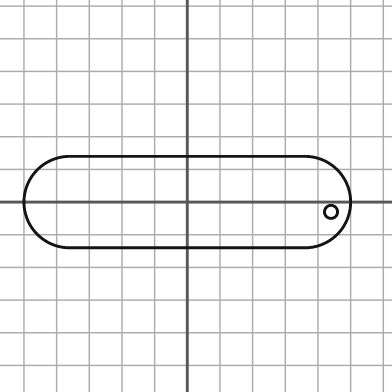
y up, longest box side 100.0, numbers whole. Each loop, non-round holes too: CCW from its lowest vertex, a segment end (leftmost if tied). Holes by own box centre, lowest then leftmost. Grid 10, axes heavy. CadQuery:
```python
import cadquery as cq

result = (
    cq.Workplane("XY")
    .moveTo(-36.0, -14.0)
    .lineTo(36.0, -14.0)
    .threePointArc((50.0, 0.0), (36.0, 14.0))
    .lineTo(-36.0, 14.0)
    .threePointArc((-50.0, 0.0), (-36.0, -14.0))
    .close()
    .moveTo(44.0, -3.0)
    .circle(2.0)
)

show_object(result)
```